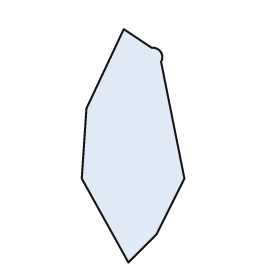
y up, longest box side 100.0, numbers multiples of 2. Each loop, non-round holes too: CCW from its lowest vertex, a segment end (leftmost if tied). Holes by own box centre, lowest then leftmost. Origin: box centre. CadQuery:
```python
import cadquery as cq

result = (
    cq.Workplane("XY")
    .moveTo(-2.0, -50.0)
    .lineTo(10.0, -38.0)
    .lineTo(22.0, -14.0)
    .lineTo(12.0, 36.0)
    .threePointArc((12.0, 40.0), (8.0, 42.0))
    .lineTo(-4.0, 50.0)
    .lineTo(-20.0, 16.0)
    .lineTo(-22.0, -14.0)
    .close()
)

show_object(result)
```